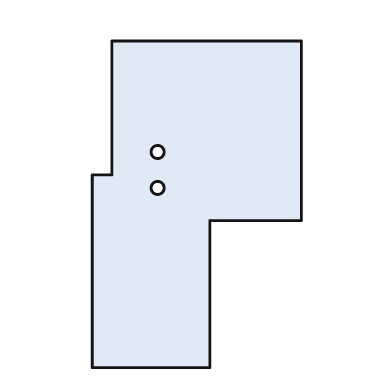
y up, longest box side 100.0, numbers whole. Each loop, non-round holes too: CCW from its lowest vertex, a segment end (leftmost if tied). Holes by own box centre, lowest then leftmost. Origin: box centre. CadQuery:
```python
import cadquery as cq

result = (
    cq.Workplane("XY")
    .moveTo(-32.0, -50.0)
    .lineTo(4.0, -50.0)
    .lineTo(4.0, -5.0)
    .lineTo(32.0, -5.0)
    .lineTo(32.0, 50.0)
    .lineTo(-26.0, 50.0)
    .lineTo(-26.0, 9.0)
    .lineTo(-32.0, 9.0)
    .close()
    .moveTo(-12.0, 5.0)
    .circle(2.0)
    .moveTo(-12.0, 16.0)
    .circle(2.0)
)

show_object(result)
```